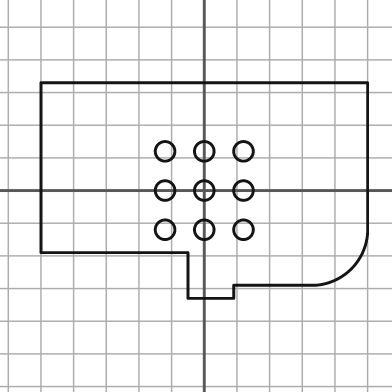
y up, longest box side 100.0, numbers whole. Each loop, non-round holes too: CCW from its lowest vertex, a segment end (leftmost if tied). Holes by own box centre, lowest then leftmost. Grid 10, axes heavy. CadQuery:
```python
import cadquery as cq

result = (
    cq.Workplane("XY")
    .moveTo(-5.0, -33.0)
    .lineTo(9.0, -33.0)
    .lineTo(9.0, -29.0)
    .lineTo(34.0, -29.0)
    .threePointArc((45.0, -24.0), (50.0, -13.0))
    .lineTo(50.0, 33.0)
    .lineTo(-50.0, 33.0)
    .lineTo(-50.0, -19.0)
    .lineTo(-5.0, -19.0)
    .close()
    .moveTo(-12.0, -12.0)
    .circle(3.0)
    .moveTo(0.0, -12.0)
    .circle(3.0)
    .moveTo(12.0, -12.0)
    .circle(3.0)
    .moveTo(-12.0, 0.0)
    .circle(3.0)
    .moveTo(0.0, 0.0)
    .circle(3.0)
    .moveTo(12.0, 0.0)
    .circle(3.0)
    .moveTo(-12.0, 12.0)
    .circle(3.0)
    .moveTo(0.0, 12.0)
    .circle(3.0)
    .moveTo(12.0, 12.0)
    .circle(3.0)
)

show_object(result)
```